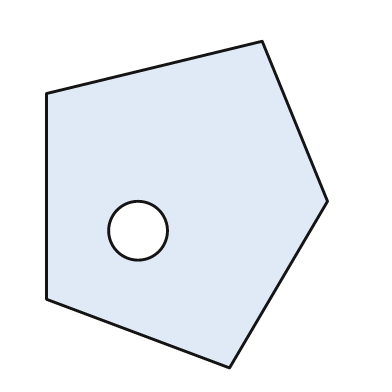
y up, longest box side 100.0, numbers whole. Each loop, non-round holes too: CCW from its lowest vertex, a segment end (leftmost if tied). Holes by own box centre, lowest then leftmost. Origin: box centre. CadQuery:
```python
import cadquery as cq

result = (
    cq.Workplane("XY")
    .moveTo(13.0, -50.0)
    .lineTo(43.0, 1.0)
    .lineTo(23.0, 50.0)
    .lineTo(-43.0, 34.0)
    .lineTo(-43.0, -29.0)
    .close()
    .moveTo(-15.0, -8.0)
    .circle(9.0)
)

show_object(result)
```